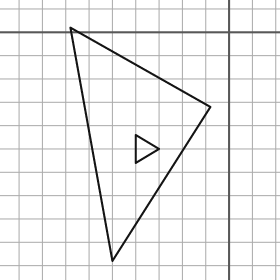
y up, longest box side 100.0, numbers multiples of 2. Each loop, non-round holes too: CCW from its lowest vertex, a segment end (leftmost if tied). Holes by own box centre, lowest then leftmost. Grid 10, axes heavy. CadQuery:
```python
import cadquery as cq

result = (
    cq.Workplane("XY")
    .moveTo(-50.0, -98.0)
    .lineTo(-8.0, -32.0)
    .lineTo(-68.0, 2.0)
    .close()
    .moveTo(-40.0, -56.0)
    .lineTo(-30.0, -50.0)
    .lineTo(-40.0, -44.0)
    .close()
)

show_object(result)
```